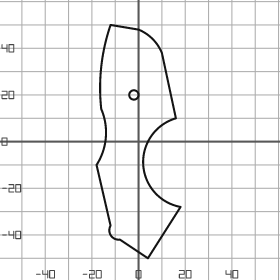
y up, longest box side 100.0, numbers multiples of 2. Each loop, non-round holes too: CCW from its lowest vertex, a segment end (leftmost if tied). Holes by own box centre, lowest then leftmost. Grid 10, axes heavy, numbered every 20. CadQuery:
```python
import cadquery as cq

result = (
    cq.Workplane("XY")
    .moveTo(4.0, -50.0)
    .lineTo(18.0, -28.0)
    .threePointArc((2.0, -10.0), (16.0, 10.0))
    .lineTo(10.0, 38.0)
    .threePointArc((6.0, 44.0), (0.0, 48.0))
    .lineTo(-12.0, 50.0)
    .threePointArc((-16.0, 32.0), (-16.0, 14.0))
    .threePointArc((-14.0, 2.0), (-18.0, -10.0))
    .lineTo(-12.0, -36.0)
    .threePointArc((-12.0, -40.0), (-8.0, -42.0))
    .close()
    .moveTo(-2.0, 20.0)
    .circle(2.0)
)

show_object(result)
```